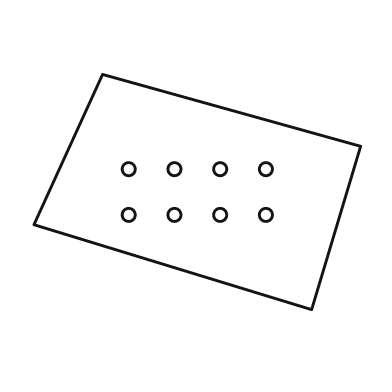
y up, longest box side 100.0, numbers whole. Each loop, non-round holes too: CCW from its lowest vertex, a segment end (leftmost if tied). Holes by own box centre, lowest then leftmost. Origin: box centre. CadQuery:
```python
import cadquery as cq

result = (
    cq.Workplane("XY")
    .moveTo(35.0, -36.0)
    .lineTo(50.0, 14.0)
    .lineTo(-29.0, 36.0)
    .lineTo(-50.0, -10.0)
    .close()
    .moveTo(-21.0, -7.0)
    .circle(2.0)
    .moveTo(-7.0, -7.0)
    .circle(2.0)
    .moveTo(7.0, -7.0)
    .circle(2.0)
    .moveTo(21.0, -7.0)
    .circle(2.0)
    .moveTo(-21.0, 7.0)
    .circle(2.0)
    .moveTo(-7.0, 7.0)
    .circle(2.0)
    .moveTo(7.0, 7.0)
    .circle(2.0)
    .moveTo(21.0, 7.0)
    .circle(2.0)
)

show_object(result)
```